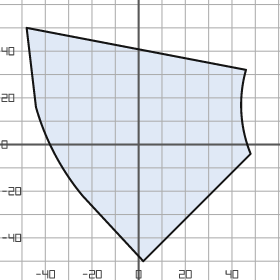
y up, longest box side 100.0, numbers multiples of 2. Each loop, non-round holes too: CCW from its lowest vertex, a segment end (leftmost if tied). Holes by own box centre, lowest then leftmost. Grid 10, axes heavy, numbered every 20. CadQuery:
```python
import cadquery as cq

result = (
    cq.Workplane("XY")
    .moveTo(2.0, -50.0)
    .lineTo(48.0, -4.0)
    .threePointArc((44.0, 14.0), (46.0, 32.0))
    .lineTo(-48.0, 50.0)
    .lineTo(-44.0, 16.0)
    .threePointArc((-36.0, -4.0), (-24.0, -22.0))
    .close()
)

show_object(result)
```